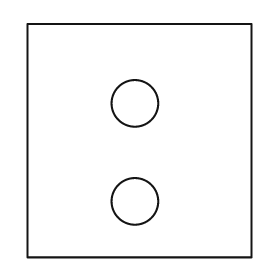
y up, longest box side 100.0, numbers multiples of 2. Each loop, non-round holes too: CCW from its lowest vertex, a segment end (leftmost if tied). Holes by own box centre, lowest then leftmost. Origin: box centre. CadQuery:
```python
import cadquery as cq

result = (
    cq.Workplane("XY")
    .moveTo(-48.0, -50.0)
    .lineTo(48.0, -50.0)
    .lineTo(48.0, 50.0)
    .lineTo(-48.0, 50.0)
    .close()
    .moveTo(-2.0, -26.0)
    .circle(10.0)
    .moveTo(-2.0, 16.0)
    .circle(10.0)
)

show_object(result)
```